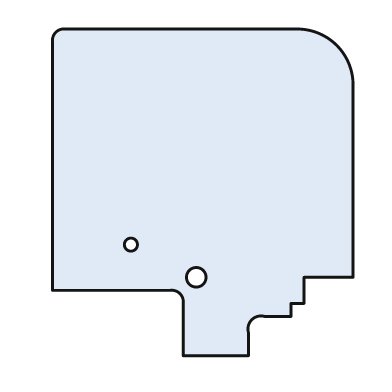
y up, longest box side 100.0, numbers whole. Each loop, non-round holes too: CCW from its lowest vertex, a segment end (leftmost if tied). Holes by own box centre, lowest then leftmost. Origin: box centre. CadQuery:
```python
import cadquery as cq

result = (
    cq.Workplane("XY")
    .moveTo(-6.0, -50.0)
    .lineTo(14.0, -50.0)
    .lineTo(14.0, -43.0)
    .threePointArc((15.0, -39.0), (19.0, -38.0))
    .lineTo(27.0, -38.0)
    .lineTo(27.0, -34.0)
    .lineTo(31.0, -34.0)
    .lineTo(31.0, -26.0)
    .lineTo(46.0, -26.0)
    .lineTo(46.0, 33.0)
    .threePointArc((41.0, 45.0), (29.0, 50.0))
    .lineTo(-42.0, 50.0)
    .threePointArc((-45.0, 49.0), (-46.0, 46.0))
    .lineTo(-46.0, -30.0)
    .lineTo(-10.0, -30.0)
    .threePointArc((-7.0, -31.0), (-6.0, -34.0))
    .close()
    .moveTo(-2.0, -26.0)
    .circle(3.0)
    .moveTo(-22.0, -16.0)
    .circle(2.0)
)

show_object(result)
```